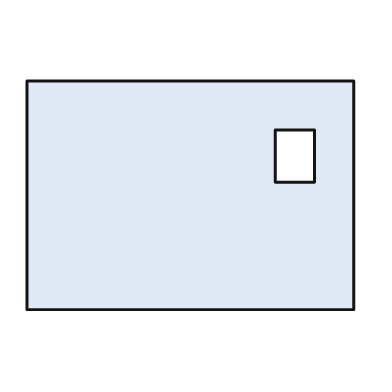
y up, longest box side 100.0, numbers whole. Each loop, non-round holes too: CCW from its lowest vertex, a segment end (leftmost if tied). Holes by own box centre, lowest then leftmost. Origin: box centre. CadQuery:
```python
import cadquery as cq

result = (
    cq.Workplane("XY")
    .moveTo(-50.0, -35.0)
    .lineTo(50.0, -35.0)
    .lineTo(50.0, 35.0)
    .lineTo(-50.0, 35.0)
    .close()
    .moveTo(26.0, 4.0)
    .lineTo(38.0, 4.0)
    .lineTo(38.0, 20.0)
    .lineTo(26.0, 20.0)
    .close()
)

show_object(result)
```